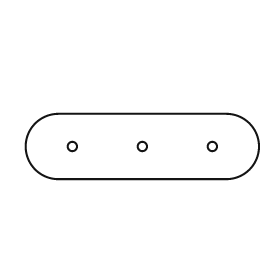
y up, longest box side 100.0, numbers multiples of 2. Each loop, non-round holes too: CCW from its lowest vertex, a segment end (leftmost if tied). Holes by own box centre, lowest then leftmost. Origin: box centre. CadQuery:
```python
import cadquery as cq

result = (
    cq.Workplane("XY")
    .moveTo(-36.0, -14.0)
    .lineTo(36.0, -14.0)
    .threePointArc((50.0, 0.0), (36.0, 14.0))
    .lineTo(-36.0, 14.0)
    .threePointArc((-50.0, 0.0), (-36.0, -14.0))
    .close()
    .moveTo(-30.0, 0.0)
    .circle(2.0)
    .moveTo(0.0, 0.0)
    .circle(2.0)
    .moveTo(30.0, 0.0)
    .circle(2.0)
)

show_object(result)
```